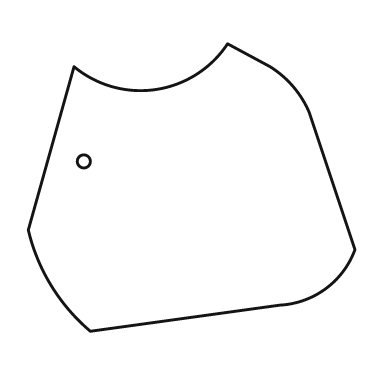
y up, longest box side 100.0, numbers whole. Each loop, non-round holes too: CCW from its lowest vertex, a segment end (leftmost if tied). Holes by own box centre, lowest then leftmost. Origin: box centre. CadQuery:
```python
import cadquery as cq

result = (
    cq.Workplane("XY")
    .moveTo(-31.0, -44.0)
    .lineTo(27.0, -36.0)
    .threePointArc((41.0, -31.0), (50.0, -19.0))
    .lineTo(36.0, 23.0)
    .threePointArc((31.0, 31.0), (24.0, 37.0))
    .lineTo(11.0, 44.0)
    .threePointArc((-11.0, 30.0), (-36.0, 37.0))
    .lineTo(-50.0, -13.0)
    .threePointArc((-43.0, -30.0), (-31.0, -44.0))
    .close()
    .moveTo(-33.0, 8.0)
    .circle(2.0)
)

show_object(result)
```